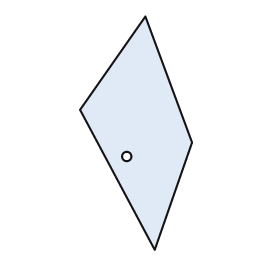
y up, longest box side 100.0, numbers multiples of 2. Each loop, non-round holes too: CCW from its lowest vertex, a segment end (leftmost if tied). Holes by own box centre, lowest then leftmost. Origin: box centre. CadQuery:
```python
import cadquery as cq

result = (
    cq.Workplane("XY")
    .moveTo(8.0, -50.0)
    .lineTo(24.0, -4.0)
    .lineTo(4.0, 50.0)
    .lineTo(-24.0, 10.0)
    .close()
    .moveTo(-4.0, -10.0)
    .circle(2.0)
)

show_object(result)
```